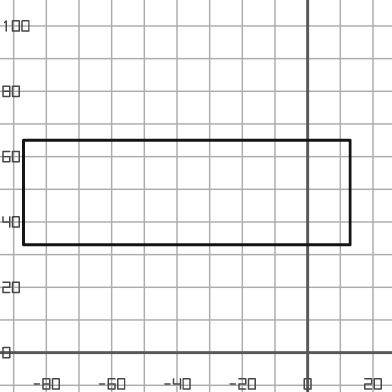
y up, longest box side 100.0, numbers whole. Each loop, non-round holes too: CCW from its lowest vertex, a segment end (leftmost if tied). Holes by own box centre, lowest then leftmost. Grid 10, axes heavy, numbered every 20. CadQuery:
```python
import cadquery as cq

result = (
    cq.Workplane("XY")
    .moveTo(-87.0, 33.0)
    .lineTo(13.0, 33.0)
    .lineTo(13.0, 65.0)
    .lineTo(-87.0, 65.0)
    .close()
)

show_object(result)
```